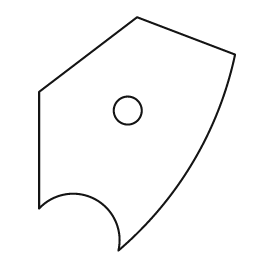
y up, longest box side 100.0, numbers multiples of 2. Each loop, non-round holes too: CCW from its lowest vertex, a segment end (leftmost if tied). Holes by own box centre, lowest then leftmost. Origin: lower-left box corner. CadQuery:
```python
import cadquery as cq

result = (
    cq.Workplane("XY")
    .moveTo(34.0, 0.0)
    .threePointArc((66.0, 38.0), (84.0, 84.0))
    .lineTo(42.0, 100.0)
    .lineTo(0.0, 68.0)
    .lineTo(0.0, 18.0)
    .threePointArc((24.0, 22.0), (34.0, 0.0))
    .close()
    .moveTo(38.0, 60.0)
    .circle(6.0)
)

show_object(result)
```